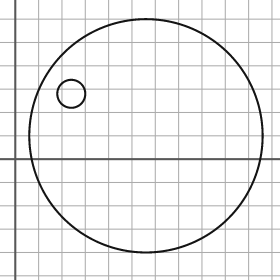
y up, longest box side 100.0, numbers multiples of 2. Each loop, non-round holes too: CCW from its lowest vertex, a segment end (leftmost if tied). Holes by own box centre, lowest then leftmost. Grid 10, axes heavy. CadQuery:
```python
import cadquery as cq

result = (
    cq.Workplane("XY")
    .moveTo(56.0, 10.0)
    .circle(50.0)
    .moveTo(24.0, 28.0)
    .circle(6.0)
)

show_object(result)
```